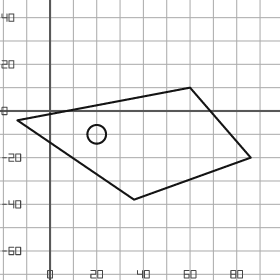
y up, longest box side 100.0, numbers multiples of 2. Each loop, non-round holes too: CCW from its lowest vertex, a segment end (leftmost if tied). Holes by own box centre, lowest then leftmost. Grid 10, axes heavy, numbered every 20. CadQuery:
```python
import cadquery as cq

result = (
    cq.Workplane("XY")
    .moveTo(36.0, -38.0)
    .lineTo(86.0, -20.0)
    .lineTo(60.0, 10.0)
    .lineTo(-14.0, -4.0)
    .close()
    .moveTo(20.0, -10.0)
    .circle(4.0)
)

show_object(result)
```